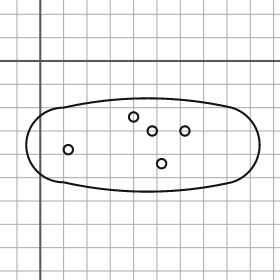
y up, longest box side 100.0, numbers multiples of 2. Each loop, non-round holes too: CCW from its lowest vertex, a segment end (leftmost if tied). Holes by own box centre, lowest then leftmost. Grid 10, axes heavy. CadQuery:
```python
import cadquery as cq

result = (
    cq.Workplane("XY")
    .moveTo(10.0, -52.0)
    .threePointArc((46.0, -56.0), (82.0, -52.0))
    .threePointArc((94.0, -36.0), (82.0, -20.0))
    .threePointArc((46.0, -16.0), (10.0, -20.0))
    .threePointArc((-6.0, -36.0), (10.0, -52.0))
    .close()
    .moveTo(52.0, -44.0)
    .circle(2.0)
    .moveTo(12.0, -38.0)
    .circle(2.0)
    .moveTo(48.0, -30.0)
    .circle(2.0)
    .moveTo(62.0, -30.0)
    .circle(2.0)
    .moveTo(40.0, -24.0)
    .circle(2.0)
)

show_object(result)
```